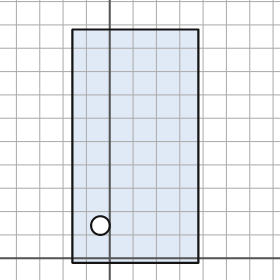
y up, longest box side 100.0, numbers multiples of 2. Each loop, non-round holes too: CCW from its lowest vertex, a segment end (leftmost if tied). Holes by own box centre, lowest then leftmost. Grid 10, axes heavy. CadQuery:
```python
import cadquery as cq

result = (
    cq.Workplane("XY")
    .moveTo(-16.0, -2.0)
    .lineTo(38.0, -2.0)
    .lineTo(38.0, 98.0)
    .lineTo(-16.0, 98.0)
    .close()
    .moveTo(-4.0, 14.0)
    .circle(4.0)
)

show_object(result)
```